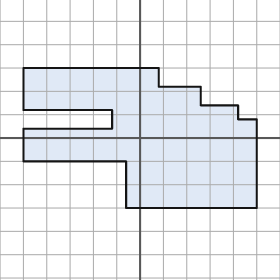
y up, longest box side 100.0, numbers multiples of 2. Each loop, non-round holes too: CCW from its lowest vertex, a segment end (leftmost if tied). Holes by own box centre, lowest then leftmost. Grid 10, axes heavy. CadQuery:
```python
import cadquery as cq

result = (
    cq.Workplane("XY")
    .moveTo(-6.0, -30.0)
    .lineTo(50.0, -30.0)
    .lineTo(50.0, 8.0)
    .lineTo(42.0, 8.0)
    .lineTo(42.0, 14.0)
    .lineTo(26.0, 14.0)
    .lineTo(26.0, 22.0)
    .lineTo(8.0, 22.0)
    .lineTo(8.0, 30.0)
    .lineTo(-50.0, 30.0)
    .lineTo(-50.0, 12.0)
    .lineTo(-12.0, 12.0)
    .lineTo(-12.0, 4.0)
    .lineTo(-50.0, 4.0)
    .lineTo(-50.0, -10.0)
    .lineTo(-6.0, -10.0)
    .close()
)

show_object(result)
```